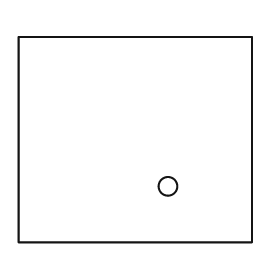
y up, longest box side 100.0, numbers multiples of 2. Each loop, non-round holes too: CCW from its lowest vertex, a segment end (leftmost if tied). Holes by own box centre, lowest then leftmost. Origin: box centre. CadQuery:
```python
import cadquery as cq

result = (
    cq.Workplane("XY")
    .moveTo(-50.0, -44.0)
    .lineTo(50.0, -44.0)
    .lineTo(50.0, 44.0)
    .lineTo(-50.0, 44.0)
    .close()
    .moveTo(14.0, -20.0)
    .circle(4.0)
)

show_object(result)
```